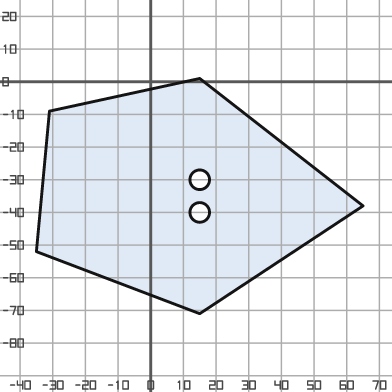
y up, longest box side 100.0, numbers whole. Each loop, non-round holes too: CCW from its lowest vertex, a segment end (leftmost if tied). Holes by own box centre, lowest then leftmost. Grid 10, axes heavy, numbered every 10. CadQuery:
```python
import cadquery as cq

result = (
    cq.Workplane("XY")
    .moveTo(15.0, -71.0)
    .lineTo(65.0, -38.0)
    .lineTo(15.0, 1.0)
    .lineTo(-31.0, -9.0)
    .lineTo(-35.0, -52.0)
    .close()
    .moveTo(15.0, -40.0)
    .circle(3.0)
    .moveTo(15.0, -30.0)
    .circle(3.0)
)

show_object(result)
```